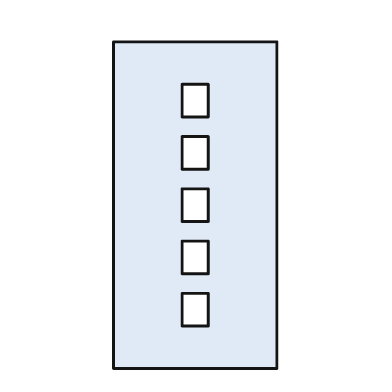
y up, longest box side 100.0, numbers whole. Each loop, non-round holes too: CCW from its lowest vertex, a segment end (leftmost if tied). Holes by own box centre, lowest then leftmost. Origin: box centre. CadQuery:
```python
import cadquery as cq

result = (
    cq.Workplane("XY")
    .moveTo(-25.0, -50.0)
    .lineTo(25.0, -50.0)
    .lineTo(25.0, 50.0)
    .lineTo(-25.0, 50.0)
    .close()
    .moveTo(-4.0, -37.0)
    .lineTo(4.0, -37.0)
    .lineTo(4.0, -27.0)
    .lineTo(-4.0, -27.0)
    .close()
    .moveTo(-4.0, -21.0)
    .lineTo(4.0, -21.0)
    .lineTo(4.0, -11.0)
    .lineTo(-4.0, -11.0)
    .close()
    .moveTo(-4.0, -5.0)
    .lineTo(4.0, -5.0)
    .lineTo(4.0, 5.0)
    .lineTo(-4.0, 5.0)
    .close()
    .moveTo(-4.0, 11.0)
    .lineTo(4.0, 11.0)
    .lineTo(4.0, 21.0)
    .lineTo(-4.0, 21.0)
    .close()
    .moveTo(-4.0, 27.0)
    .lineTo(4.0, 27.0)
    .lineTo(4.0, 37.0)
    .lineTo(-4.0, 37.0)
    .close()
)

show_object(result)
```